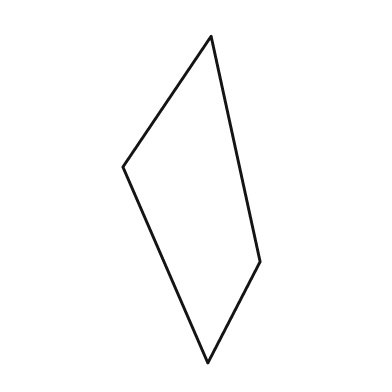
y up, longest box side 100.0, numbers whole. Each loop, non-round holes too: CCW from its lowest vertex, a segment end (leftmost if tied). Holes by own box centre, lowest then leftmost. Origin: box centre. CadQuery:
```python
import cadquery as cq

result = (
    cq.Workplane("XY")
    .moveTo(5.0, -50.0)
    .lineTo(21.0, -19.0)
    .lineTo(6.0, 50.0)
    .lineTo(-21.0, 10.0)
    .close()
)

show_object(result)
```